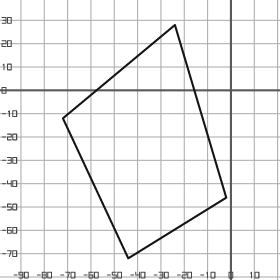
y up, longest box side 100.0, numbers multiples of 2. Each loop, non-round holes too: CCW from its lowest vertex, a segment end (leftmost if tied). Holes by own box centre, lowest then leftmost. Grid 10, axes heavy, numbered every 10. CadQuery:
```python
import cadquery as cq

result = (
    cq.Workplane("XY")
    .moveTo(-44.0, -72.0)
    .lineTo(-2.0, -46.0)
    .lineTo(-24.0, 28.0)
    .lineTo(-72.0, -12.0)
    .close()
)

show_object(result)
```